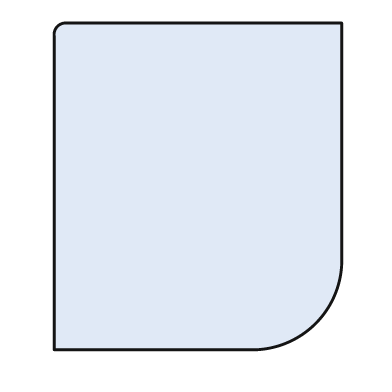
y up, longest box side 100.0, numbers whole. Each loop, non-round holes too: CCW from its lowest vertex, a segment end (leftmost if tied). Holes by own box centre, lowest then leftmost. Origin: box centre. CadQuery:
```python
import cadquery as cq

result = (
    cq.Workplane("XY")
    .moveTo(-44.0, -50.0)
    .lineTo(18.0, -50.0)
    .threePointArc((36.0, -42.0), (44.0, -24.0))
    .lineTo(44.0, 50.0)
    .lineTo(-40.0, 50.0)
    .threePointArc((-43.0, 49.0), (-44.0, 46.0))
    .close()
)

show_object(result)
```